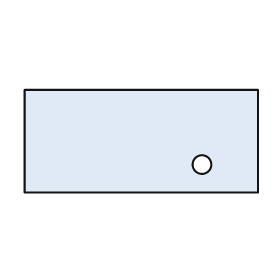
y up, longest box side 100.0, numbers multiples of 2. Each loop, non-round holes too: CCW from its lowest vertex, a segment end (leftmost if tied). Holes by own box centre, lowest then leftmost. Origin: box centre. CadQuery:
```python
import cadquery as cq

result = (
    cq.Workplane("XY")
    .moveTo(-50.0, -22.0)
    .lineTo(50.0, -22.0)
    .lineTo(50.0, 22.0)
    .lineTo(-50.0, 22.0)
    .close()
    .moveTo(26.0, -10.0)
    .circle(4.0)
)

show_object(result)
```